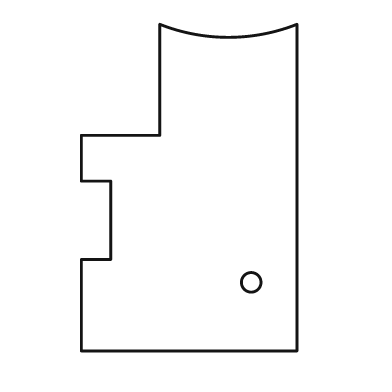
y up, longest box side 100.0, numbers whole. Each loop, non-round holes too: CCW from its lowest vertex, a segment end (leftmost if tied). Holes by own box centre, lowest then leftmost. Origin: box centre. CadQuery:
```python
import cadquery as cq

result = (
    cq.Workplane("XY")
    .moveTo(-33.0, -50.0)
    .lineTo(33.0, -50.0)
    .lineTo(33.0, 50.0)
    .threePointArc((12.0, 46.0), (-9.0, 50.0))
    .lineTo(-9.0, 16.0)
    .lineTo(-33.0, 16.0)
    .lineTo(-33.0, 2.0)
    .lineTo(-24.0, 2.0)
    .lineTo(-24.0, -22.0)
    .lineTo(-33.0, -22.0)
    .close()
    .moveTo(19.0, -29.0)
    .circle(3.0)
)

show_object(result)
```